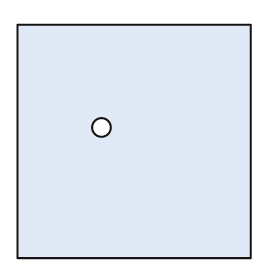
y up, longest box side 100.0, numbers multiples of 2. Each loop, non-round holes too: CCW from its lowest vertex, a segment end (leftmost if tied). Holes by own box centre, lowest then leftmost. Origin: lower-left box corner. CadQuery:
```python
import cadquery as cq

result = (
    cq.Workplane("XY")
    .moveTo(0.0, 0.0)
    .lineTo(100.0, 0.0)
    .lineTo(100.0, 100.0)
    .lineTo(0.0, 100.0)
    .close()
    .moveTo(36.0, 56.0)
    .circle(4.0)
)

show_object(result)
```